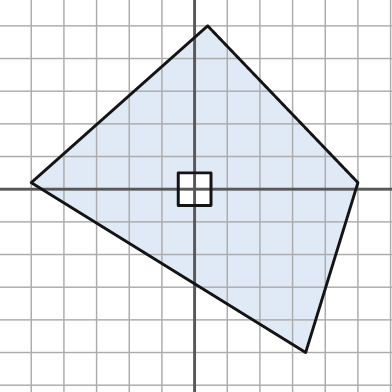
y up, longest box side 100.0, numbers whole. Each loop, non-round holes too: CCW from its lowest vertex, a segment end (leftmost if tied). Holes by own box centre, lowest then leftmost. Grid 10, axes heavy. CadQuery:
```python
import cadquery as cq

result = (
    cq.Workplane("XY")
    .moveTo(34.0, -50.0)
    .lineTo(50.0, 2.0)
    .lineTo(4.0, 50.0)
    .lineTo(-50.0, 2.0)
    .close()
    .moveTo(-5.0, -5.0)
    .lineTo(5.0, -5.0)
    .lineTo(5.0, 5.0)
    .lineTo(-5.0, 5.0)
    .close()
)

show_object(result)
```